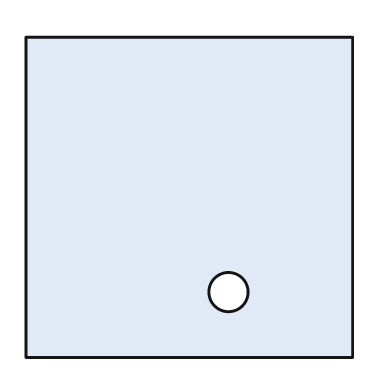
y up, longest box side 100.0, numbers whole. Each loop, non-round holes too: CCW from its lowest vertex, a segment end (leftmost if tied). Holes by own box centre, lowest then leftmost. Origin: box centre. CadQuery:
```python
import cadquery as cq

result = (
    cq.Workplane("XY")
    .moveTo(-50.0, -49.0)
    .lineTo(50.0, -49.0)
    .lineTo(50.0, 49.0)
    .lineTo(-50.0, 49.0)
    .close()
    .moveTo(12.0, -29.0)
    .circle(6.0)
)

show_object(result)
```